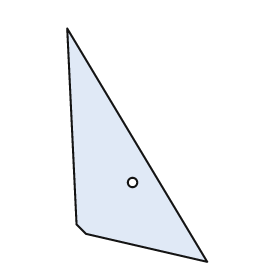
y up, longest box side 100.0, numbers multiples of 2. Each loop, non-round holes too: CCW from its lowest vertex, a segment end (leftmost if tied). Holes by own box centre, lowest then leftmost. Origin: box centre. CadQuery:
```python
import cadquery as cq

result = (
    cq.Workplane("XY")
    .moveTo(30.0, -50.0)
    .lineTo(-30.0, 50.0)
    .lineTo(-26.0, -34.0)
    .lineTo(-22.0, -38.0)
    .close()
    .moveTo(-2.0, -16.0)
    .circle(2.0)
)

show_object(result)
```